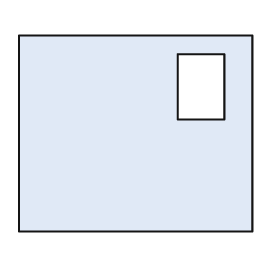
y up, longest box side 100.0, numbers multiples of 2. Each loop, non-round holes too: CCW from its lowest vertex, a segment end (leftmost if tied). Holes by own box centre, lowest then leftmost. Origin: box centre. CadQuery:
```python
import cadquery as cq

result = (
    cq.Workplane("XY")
    .moveTo(-50.0, -42.0)
    .lineTo(50.0, -42.0)
    .lineTo(50.0, 42.0)
    .lineTo(-50.0, 42.0)
    .close()
    .moveTo(18.0, 6.0)
    .lineTo(38.0, 6.0)
    .lineTo(38.0, 34.0)
    .lineTo(18.0, 34.0)
    .close()
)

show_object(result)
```